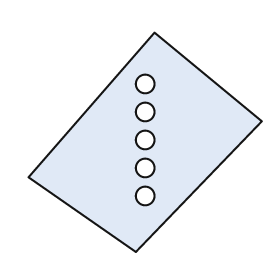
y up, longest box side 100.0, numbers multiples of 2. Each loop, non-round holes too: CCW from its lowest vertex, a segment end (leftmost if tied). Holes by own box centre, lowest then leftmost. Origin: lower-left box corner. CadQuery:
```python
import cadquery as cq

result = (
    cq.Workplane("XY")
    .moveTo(46.0, 0.0)
    .lineTo(100.0, 56.0)
    .lineTo(54.0, 94.0)
    .lineTo(0.0, 32.0)
    .close()
    .moveTo(50.0, 24.0)
    .circle(4.0)
    .moveTo(50.0, 36.0)
    .circle(4.0)
    .moveTo(50.0, 48.0)
    .circle(4.0)
    .moveTo(50.0, 60.0)
    .circle(4.0)
    .moveTo(50.0, 72.0)
    .circle(4.0)
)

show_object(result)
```